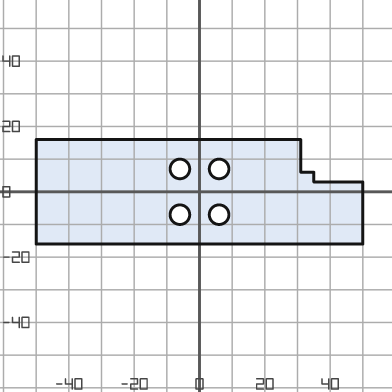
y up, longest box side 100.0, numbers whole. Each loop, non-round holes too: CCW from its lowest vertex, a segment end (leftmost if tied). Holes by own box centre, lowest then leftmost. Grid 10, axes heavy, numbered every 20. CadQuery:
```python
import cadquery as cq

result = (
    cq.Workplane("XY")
    .moveTo(-50.0, -16.0)
    .lineTo(50.0, -16.0)
    .lineTo(50.0, 3.0)
    .lineTo(35.0, 3.0)
    .lineTo(35.0, 6.0)
    .lineTo(31.0, 6.0)
    .lineTo(31.0, 16.0)
    .lineTo(-50.0, 16.0)
    .close()
    .moveTo(-6.0, -7.0)
    .circle(3.0)
    .moveTo(6.0, -7.0)
    .circle(3.0)
    .moveTo(-6.0, 7.0)
    .circle(3.0)
    .moveTo(6.0, 7.0)
    .circle(3.0)
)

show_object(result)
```